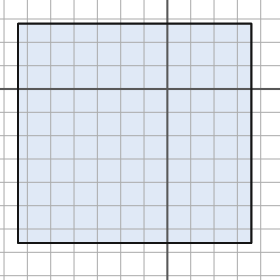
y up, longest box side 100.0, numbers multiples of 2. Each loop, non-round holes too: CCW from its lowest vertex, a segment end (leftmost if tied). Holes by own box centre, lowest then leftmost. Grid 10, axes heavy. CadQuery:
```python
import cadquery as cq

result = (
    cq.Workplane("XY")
    .moveTo(-64.0, -66.0)
    .lineTo(36.0, -66.0)
    .lineTo(36.0, 28.0)
    .lineTo(-64.0, 28.0)
    .close()
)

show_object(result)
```